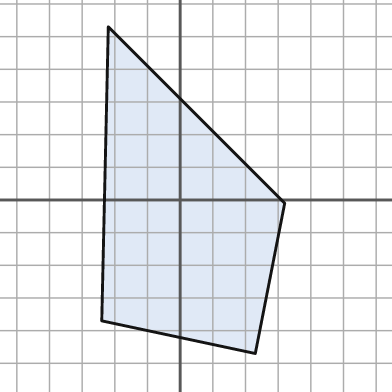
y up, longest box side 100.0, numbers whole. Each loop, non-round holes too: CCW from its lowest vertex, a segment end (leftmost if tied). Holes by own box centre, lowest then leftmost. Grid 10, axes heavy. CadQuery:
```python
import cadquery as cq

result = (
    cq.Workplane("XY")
    .moveTo(23.0, -47.0)
    .lineTo(32.0, -1.0)
    .lineTo(-22.0, 53.0)
    .lineTo(-24.0, -37.0)
    .close()
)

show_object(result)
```